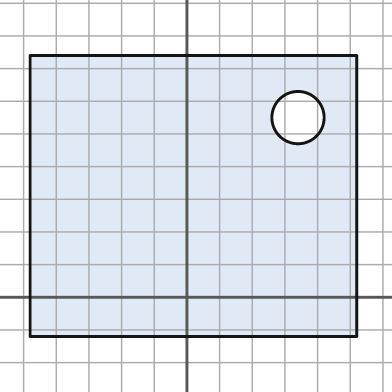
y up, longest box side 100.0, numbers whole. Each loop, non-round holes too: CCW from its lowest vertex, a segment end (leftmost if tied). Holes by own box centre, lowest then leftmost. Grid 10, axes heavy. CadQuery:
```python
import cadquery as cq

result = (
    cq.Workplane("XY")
    .moveTo(-48.0, -12.0)
    .lineTo(52.0, -12.0)
    .lineTo(52.0, 74.0)
    .lineTo(-48.0, 74.0)
    .close()
    .moveTo(34.0, 55.0)
    .circle(8.0)
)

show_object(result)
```